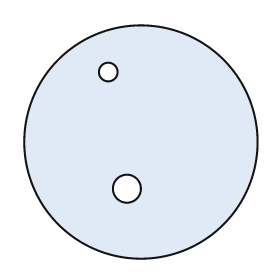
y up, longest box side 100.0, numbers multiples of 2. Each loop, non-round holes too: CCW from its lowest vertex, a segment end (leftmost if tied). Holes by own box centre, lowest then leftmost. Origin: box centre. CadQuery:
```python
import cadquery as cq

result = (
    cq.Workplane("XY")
    .moveTo(0.0, 0.0)
    .circle(50.0)
    .moveTo(-6.0, -20.0)
    .circle(6.0)
    .moveTo(-14.0, 30.0)
    .circle(4.0)
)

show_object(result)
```